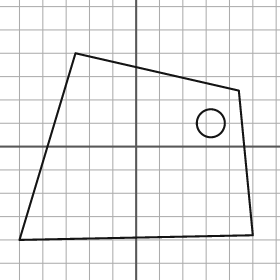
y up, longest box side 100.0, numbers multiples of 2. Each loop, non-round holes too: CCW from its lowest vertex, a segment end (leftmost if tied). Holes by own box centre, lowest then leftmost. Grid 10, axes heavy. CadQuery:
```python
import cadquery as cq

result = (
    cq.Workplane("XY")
    .moveTo(-50.0, -40.0)
    .lineTo(50.0, -38.0)
    .lineTo(44.0, 24.0)
    .lineTo(-26.0, 40.0)
    .close()
    .moveTo(32.0, 10.0)
    .circle(6.0)
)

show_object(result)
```